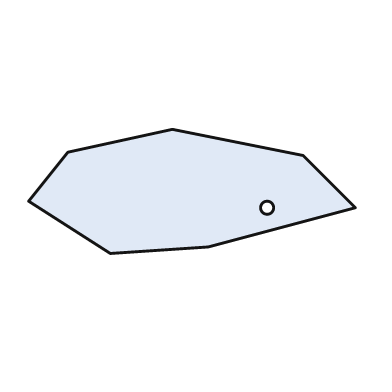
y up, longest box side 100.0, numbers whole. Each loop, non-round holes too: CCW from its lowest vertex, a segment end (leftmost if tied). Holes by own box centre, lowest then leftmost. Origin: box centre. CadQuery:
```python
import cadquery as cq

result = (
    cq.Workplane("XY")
    .moveTo(-25.0, -19.0)
    .lineTo(5.0, -17.0)
    .lineTo(50.0, -5.0)
    .lineTo(34.0, 11.0)
    .lineTo(-6.0, 19.0)
    .lineTo(-38.0, 12.0)
    .lineTo(-50.0, -3.0)
    .close()
    .moveTo(23.0, -5.0)
    .circle(2.0)
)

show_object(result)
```